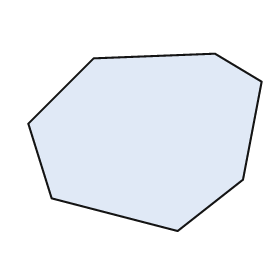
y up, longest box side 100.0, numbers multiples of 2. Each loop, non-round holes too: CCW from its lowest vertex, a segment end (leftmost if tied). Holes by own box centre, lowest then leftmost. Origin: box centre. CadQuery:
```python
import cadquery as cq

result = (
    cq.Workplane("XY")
    .moveTo(14.0, -38.0)
    .lineTo(42.0, -16.0)
    .lineTo(50.0, 26.0)
    .lineTo(30.0, 38.0)
    .lineTo(-22.0, 36.0)
    .lineTo(-50.0, 8.0)
    .lineTo(-40.0, -24.0)
    .close()
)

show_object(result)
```